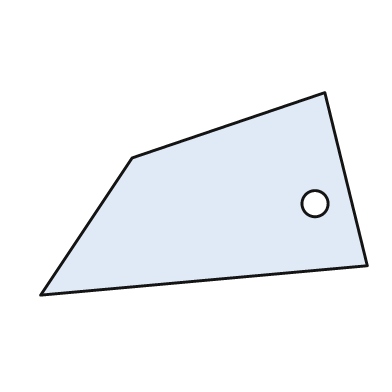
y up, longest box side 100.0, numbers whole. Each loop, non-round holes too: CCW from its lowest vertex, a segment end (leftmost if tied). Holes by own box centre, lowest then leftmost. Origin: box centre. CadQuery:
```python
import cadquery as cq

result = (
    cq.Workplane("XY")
    .moveTo(-50.0, -31.0)
    .lineTo(50.0, -22.0)
    .lineTo(37.0, 31.0)
    .lineTo(-22.0, 11.0)
    .close()
    .moveTo(34.0, -3.0)
    .circle(4.0)
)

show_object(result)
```